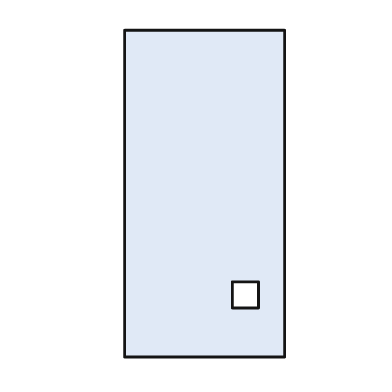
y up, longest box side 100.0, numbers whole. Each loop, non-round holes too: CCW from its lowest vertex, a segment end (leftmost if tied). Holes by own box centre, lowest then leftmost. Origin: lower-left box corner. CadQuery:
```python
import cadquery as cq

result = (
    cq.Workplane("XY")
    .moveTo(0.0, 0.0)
    .lineTo(49.0, 0.0)
    .lineTo(49.0, 100.0)
    .lineTo(0.0, 100.0)
    .close()
    .moveTo(33.0, 15.0)
    .lineTo(41.0, 15.0)
    .lineTo(41.0, 23.0)
    .lineTo(33.0, 23.0)
    .close()
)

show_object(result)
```